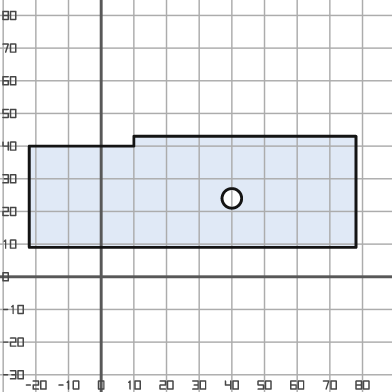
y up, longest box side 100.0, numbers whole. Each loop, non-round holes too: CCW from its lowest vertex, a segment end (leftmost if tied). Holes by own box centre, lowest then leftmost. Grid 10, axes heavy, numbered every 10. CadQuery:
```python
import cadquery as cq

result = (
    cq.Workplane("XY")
    .moveTo(-22.0, 9.0)
    .lineTo(78.0, 9.0)
    .lineTo(78.0, 43.0)
    .lineTo(10.0, 43.0)
    .lineTo(10.0, 40.0)
    .lineTo(-22.0, 40.0)
    .close()
    .moveTo(40.0, 24.0)
    .circle(3.0)
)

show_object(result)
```